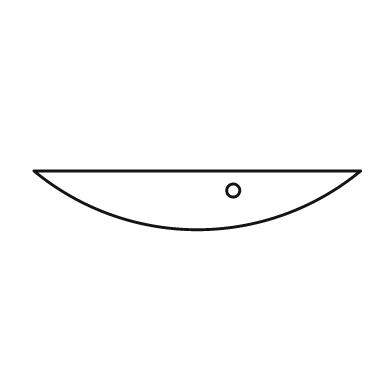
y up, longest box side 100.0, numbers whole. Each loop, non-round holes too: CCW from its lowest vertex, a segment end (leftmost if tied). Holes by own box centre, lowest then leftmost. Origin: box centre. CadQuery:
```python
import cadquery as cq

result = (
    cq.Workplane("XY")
    .moveTo(-50.0, 9.0)
    .threePointArc((0.0, -9.0), (50.0, 9.0))
    .close()
    .moveTo(11.0, 3.0)
    .circle(2.0)
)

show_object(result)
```